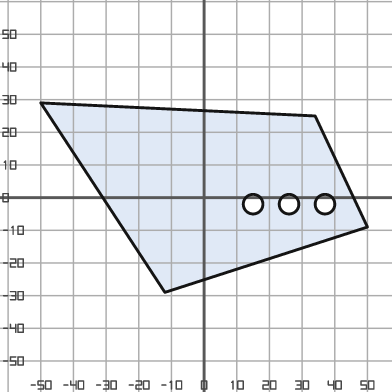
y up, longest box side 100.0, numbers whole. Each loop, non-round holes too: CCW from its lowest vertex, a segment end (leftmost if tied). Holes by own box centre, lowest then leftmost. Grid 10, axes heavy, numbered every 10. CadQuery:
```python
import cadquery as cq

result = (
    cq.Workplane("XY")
    .moveTo(-12.0, -29.0)
    .lineTo(50.0, -9.0)
    .lineTo(34.0, 25.0)
    .lineTo(-50.0, 29.0)
    .close()
    .moveTo(15.0, -2.0)
    .circle(3.0)
    .moveTo(26.0, -2.0)
    .circle(3.0)
    .moveTo(37.0, -2.0)
    .circle(3.0)
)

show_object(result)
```